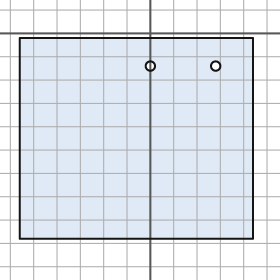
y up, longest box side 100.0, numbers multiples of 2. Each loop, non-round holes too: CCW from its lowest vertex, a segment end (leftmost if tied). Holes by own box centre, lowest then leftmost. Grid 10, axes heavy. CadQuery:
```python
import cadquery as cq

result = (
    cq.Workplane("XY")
    .moveTo(-56.0, -88.0)
    .lineTo(44.0, -88.0)
    .lineTo(44.0, -2.0)
    .lineTo(-56.0, -2.0)
    .close()
    .moveTo(0.0, -14.0)
    .circle(2.0)
    .moveTo(28.0, -14.0)
    .circle(2.0)
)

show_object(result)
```